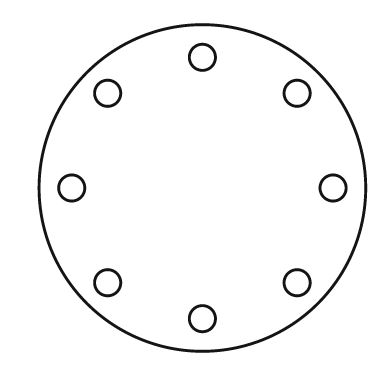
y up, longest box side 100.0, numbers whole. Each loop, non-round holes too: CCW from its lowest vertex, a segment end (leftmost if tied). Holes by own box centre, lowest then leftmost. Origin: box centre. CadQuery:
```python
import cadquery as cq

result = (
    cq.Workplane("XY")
    .moveTo(0.0, 0.0)
    .circle(50.0)
    .moveTo(0.0, -40.0)
    .circle(4.0)
    .moveTo(-29.0, -29.0)
    .circle(4.0)
    .moveTo(29.0, -29.0)
    .circle(4.0)
    .moveTo(-40.0, 0.0)
    .circle(4.0)
    .moveTo(40.0, 0.0)
    .circle(4.0)
    .moveTo(-29.0, 29.0)
    .circle(4.0)
    .moveTo(29.0, 29.0)
    .circle(4.0)
    .moveTo(0.0, 40.0)
    .circle(4.0)
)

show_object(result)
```